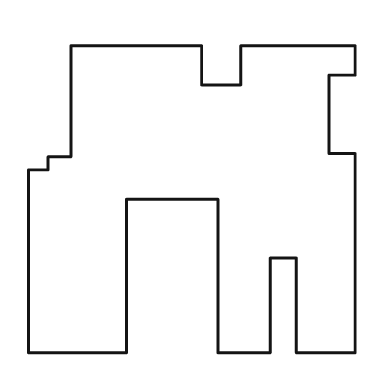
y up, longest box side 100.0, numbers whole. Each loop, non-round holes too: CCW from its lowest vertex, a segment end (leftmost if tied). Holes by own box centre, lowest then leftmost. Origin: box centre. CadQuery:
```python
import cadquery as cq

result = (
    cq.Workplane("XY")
    .moveTo(-50.0, -47.0)
    .lineTo(-20.0, -47.0)
    .lineTo(-20.0, 0.0)
    .lineTo(8.0, 0.0)
    .lineTo(8.0, -47.0)
    .lineTo(24.0, -47.0)
    .lineTo(24.0, -18.0)
    .lineTo(32.0, -18.0)
    .lineTo(32.0, -47.0)
    .lineTo(50.0, -47.0)
    .lineTo(50.0, 14.0)
    .lineTo(42.0, 14.0)
    .lineTo(42.0, 38.0)
    .lineTo(50.0, 38.0)
    .lineTo(50.0, 47.0)
    .lineTo(15.0, 47.0)
    .lineTo(15.0, 35.0)
    .lineTo(3.0, 35.0)
    .lineTo(3.0, 47.0)
    .lineTo(-37.0, 47.0)
    .lineTo(-37.0, 13.0)
    .lineTo(-44.0, 13.0)
    .lineTo(-44.0, 9.0)
    .lineTo(-50.0, 9.0)
    .close()
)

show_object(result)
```